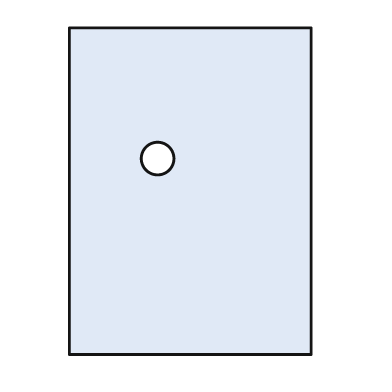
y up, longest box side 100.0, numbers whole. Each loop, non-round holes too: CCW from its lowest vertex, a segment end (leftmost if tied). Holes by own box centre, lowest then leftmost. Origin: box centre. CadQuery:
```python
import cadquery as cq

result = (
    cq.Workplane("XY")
    .moveTo(-37.0, -50.0)
    .lineTo(37.0, -50.0)
    .lineTo(37.0, 50.0)
    .lineTo(-37.0, 50.0)
    .close()
    .moveTo(-10.0, 10.0)
    .circle(5.0)
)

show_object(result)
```